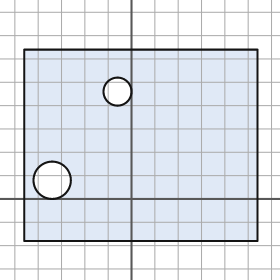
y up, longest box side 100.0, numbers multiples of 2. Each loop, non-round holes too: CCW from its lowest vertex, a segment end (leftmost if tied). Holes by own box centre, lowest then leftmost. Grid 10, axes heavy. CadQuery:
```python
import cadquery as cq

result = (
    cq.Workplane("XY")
    .moveTo(-46.0, -18.0)
    .lineTo(54.0, -18.0)
    .lineTo(54.0, 64.0)
    .lineTo(-46.0, 64.0)
    .close()
    .moveTo(-34.0, 8.0)
    .circle(8.0)
    .moveTo(-6.0, 46.0)
    .circle(6.0)
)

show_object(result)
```